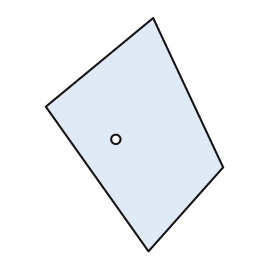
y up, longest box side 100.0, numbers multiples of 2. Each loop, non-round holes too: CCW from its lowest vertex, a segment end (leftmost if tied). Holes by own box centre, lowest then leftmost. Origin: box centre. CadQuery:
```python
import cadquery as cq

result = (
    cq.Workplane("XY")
    .moveTo(6.0, -50.0)
    .lineTo(38.0, -14.0)
    .lineTo(8.0, 50.0)
    .lineTo(-38.0, 12.0)
    .close()
    .moveTo(-8.0, -2.0)
    .circle(2.0)
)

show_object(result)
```